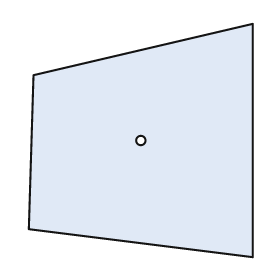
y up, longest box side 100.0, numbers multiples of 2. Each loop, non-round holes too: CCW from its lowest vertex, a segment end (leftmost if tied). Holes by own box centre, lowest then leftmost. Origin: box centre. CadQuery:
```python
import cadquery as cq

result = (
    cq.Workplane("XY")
    .moveTo(48.0, -50.0)
    .lineTo(48.0, 50.0)
    .lineTo(-46.0, 28.0)
    .lineTo(-48.0, -38.0)
    .close()
    .moveTo(0.0, 0.0)
    .circle(2.0)
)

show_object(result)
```